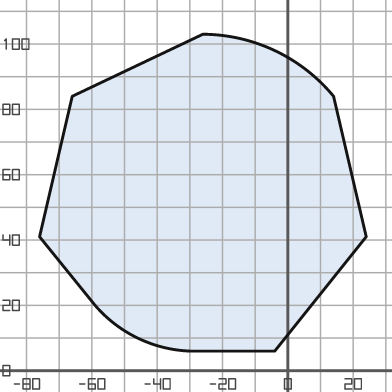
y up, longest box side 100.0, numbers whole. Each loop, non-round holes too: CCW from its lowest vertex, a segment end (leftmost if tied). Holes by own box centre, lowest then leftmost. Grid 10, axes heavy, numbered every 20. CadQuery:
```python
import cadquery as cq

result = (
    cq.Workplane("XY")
    .moveTo(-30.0, 6.0)
    .lineTo(-4.0, 6.0)
    .lineTo(24.0, 41.0)
    .lineTo(14.0, 84.0)
    .threePointArc((-4.0, 98.0), (-26.0, 103.0))
    .lineTo(-66.0, 84.0)
    .lineTo(-76.0, 41.0)
    .lineTo(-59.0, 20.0)
    .threePointArc((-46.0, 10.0), (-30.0, 6.0))
    .close()
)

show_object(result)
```